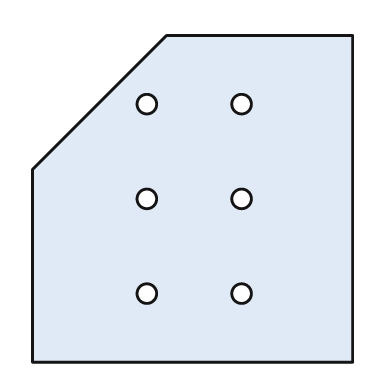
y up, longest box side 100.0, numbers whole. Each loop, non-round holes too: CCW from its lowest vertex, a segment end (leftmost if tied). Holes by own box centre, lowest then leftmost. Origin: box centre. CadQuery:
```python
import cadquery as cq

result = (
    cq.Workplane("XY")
    .moveTo(-49.0, -50.0)
    .lineTo(49.0, -50.0)
    .lineTo(49.0, 50.0)
    .lineTo(-8.0, 50.0)
    .lineTo(-49.0, 9.0)
    .close()
    .moveTo(-14.0, -29.0)
    .circle(3.0)
    .moveTo(15.0, -29.0)
    .circle(3.0)
    .moveTo(-14.0, 0.0)
    .circle(3.0)
    .moveTo(15.0, 0.0)
    .circle(3.0)
    .moveTo(-14.0, 29.0)
    .circle(3.0)
    .moveTo(15.0, 29.0)
    .circle(3.0)
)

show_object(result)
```